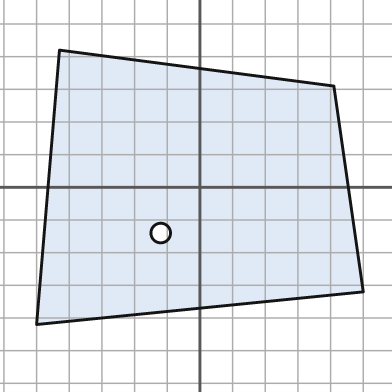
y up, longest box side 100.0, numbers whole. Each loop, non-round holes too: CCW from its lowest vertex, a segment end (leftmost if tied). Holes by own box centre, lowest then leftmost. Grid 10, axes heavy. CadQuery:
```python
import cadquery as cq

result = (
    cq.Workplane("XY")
    .moveTo(-50.0, -42.0)
    .lineTo(50.0, -32.0)
    .lineTo(41.0, 31.0)
    .lineTo(-43.0, 42.0)
    .close()
    .moveTo(-12.0, -14.0)
    .circle(3.0)
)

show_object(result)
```